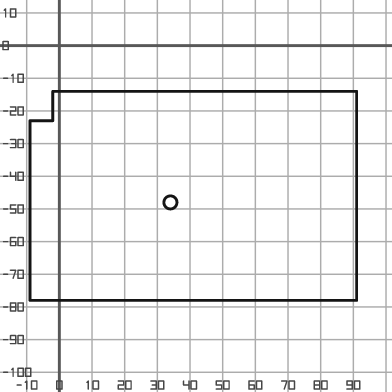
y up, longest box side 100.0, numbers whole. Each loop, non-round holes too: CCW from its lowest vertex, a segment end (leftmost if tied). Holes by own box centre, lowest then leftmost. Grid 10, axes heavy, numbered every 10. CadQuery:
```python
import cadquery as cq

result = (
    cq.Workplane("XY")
    .moveTo(-9.0, -78.0)
    .lineTo(91.0, -78.0)
    .lineTo(91.0, -14.0)
    .lineTo(-2.0, -14.0)
    .lineTo(-2.0, -23.0)
    .lineTo(-9.0, -23.0)
    .close()
    .moveTo(34.0, -48.0)
    .circle(2.0)
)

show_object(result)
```